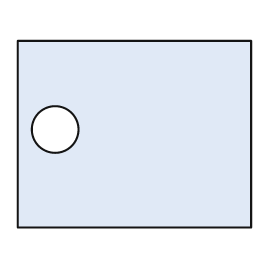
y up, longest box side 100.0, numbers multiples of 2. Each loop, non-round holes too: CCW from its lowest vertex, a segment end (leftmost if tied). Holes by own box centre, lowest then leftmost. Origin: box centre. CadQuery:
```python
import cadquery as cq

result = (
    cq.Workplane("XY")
    .moveTo(-50.0, -40.0)
    .lineTo(50.0, -40.0)
    .lineTo(50.0, 40.0)
    .lineTo(-50.0, 40.0)
    .close()
    .moveTo(-34.0, 2.0)
    .circle(10.0)
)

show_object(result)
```